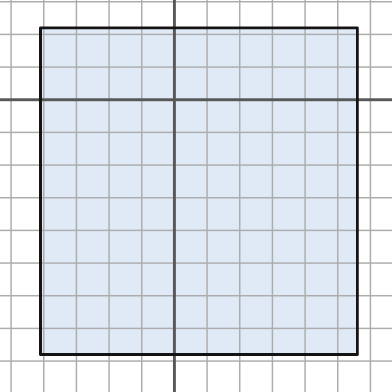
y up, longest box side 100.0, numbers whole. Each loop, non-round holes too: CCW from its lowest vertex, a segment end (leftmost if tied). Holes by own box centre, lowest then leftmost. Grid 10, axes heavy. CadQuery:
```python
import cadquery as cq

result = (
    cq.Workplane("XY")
    .moveTo(-41.0, -78.0)
    .lineTo(56.0, -78.0)
    .lineTo(56.0, 22.0)
    .lineTo(-41.0, 22.0)
    .close()
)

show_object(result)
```